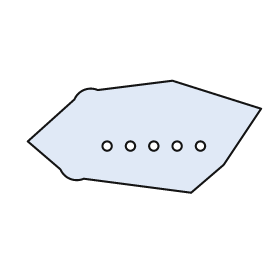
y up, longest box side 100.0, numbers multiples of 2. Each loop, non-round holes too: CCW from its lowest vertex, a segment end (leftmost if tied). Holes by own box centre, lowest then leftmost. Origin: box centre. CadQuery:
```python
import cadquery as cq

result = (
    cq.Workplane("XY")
    .moveTo(20.0, -24.0)
    .lineTo(34.0, -12.0)
    .lineTo(50.0, 12.0)
    .lineTo(12.0, 24.0)
    .lineTo(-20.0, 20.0)
    .threePointArc((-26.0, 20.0), (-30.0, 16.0))
    .lineTo(-50.0, -2.0)
    .lineTo(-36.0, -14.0)
    .threePointArc((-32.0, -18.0), (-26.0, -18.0))
    .close()
    .moveTo(-16.0, -4.0)
    .circle(2.0)
    .moveTo(-6.0, -4.0)
    .circle(2.0)
    .moveTo(4.0, -4.0)
    .circle(2.0)
    .moveTo(14.0, -4.0)
    .circle(2.0)
    .moveTo(24.0, -4.0)
    .circle(2.0)
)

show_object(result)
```